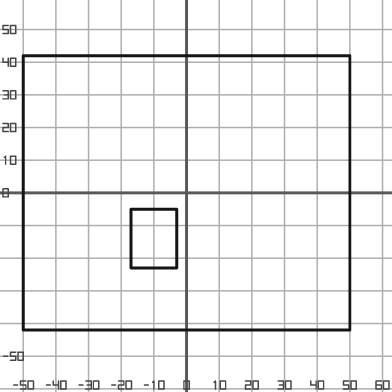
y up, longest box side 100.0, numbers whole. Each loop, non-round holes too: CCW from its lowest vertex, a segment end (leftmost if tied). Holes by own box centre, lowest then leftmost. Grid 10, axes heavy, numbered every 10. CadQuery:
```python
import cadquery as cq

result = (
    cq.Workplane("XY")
    .moveTo(-50.0, -42.0)
    .lineTo(50.0, -42.0)
    .lineTo(50.0, 42.0)
    .lineTo(-50.0, 42.0)
    .close()
    .moveTo(-17.0, -23.0)
    .lineTo(-3.0, -23.0)
    .lineTo(-3.0, -5.0)
    .lineTo(-17.0, -5.0)
    .close()
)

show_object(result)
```